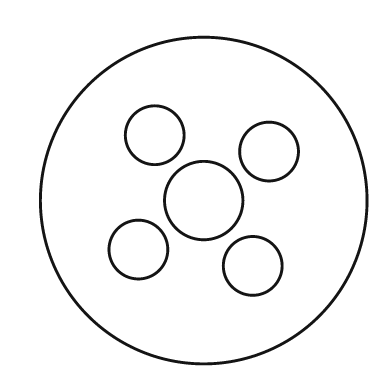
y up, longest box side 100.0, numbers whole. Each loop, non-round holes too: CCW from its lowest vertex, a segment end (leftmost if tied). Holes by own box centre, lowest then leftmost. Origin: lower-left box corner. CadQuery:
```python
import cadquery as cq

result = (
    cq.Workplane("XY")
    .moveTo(50.0, 50.0)
    .circle(50.0)
    .moveTo(65.0, 30.0)
    .circle(9.0)
    .moveTo(30.0, 35.0)
    .circle(9.0)
    .moveTo(50.0, 50.0)
    .circle(12.0)
    .moveTo(70.0, 65.0)
    .circle(9.0)
    .moveTo(35.0, 70.0)
    .circle(9.0)
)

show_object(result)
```